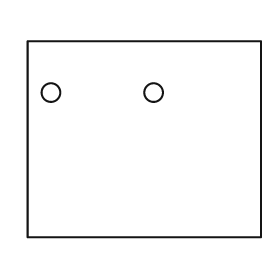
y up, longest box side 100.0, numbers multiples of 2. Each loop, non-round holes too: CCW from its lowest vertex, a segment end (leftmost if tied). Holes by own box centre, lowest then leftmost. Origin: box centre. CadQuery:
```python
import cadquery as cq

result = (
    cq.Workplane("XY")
    .moveTo(-50.0, -42.0)
    .lineTo(50.0, -42.0)
    .lineTo(50.0, 42.0)
    .lineTo(-50.0, 42.0)
    .close()
    .moveTo(-40.0, 20.0)
    .circle(4.0)
    .moveTo(4.0, 20.0)
    .circle(4.0)
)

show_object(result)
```